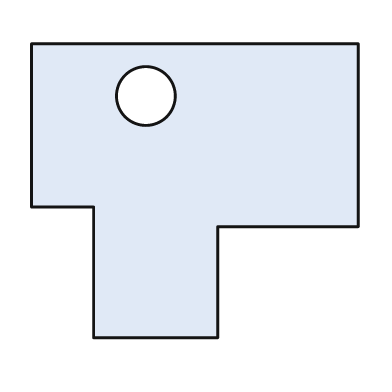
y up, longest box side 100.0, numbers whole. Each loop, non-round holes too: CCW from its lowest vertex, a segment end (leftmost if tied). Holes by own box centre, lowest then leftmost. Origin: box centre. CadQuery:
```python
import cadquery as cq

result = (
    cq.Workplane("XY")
    .moveTo(-31.0, -45.0)
    .lineTo(7.0, -45.0)
    .lineTo(7.0, -11.0)
    .lineTo(50.0, -11.0)
    .lineTo(50.0, 45.0)
    .lineTo(-50.0, 45.0)
    .lineTo(-50.0, -5.0)
    .lineTo(-31.0, -5.0)
    .close()
    .moveTo(-15.0, 29.0)
    .circle(9.0)
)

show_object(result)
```